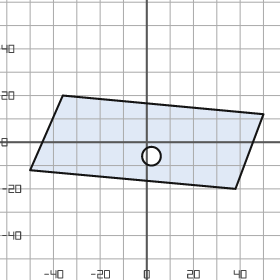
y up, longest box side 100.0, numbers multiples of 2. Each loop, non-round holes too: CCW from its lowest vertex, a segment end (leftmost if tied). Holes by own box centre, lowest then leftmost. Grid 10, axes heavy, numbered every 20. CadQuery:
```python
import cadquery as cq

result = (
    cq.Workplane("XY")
    .moveTo(38.0, -20.0)
    .lineTo(50.0, 12.0)
    .lineTo(-36.0, 20.0)
    .lineTo(-50.0, -12.0)
    .close()
    .moveTo(2.0, -6.0)
    .circle(4.0)
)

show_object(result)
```